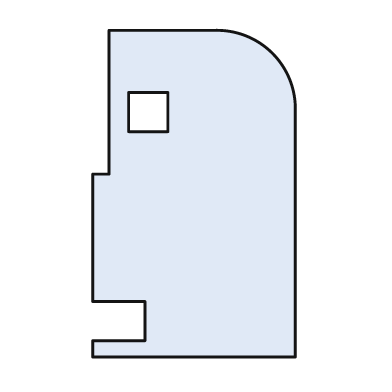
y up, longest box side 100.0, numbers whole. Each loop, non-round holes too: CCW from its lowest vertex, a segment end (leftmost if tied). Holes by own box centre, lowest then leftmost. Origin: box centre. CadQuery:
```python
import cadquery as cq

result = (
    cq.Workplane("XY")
    .moveTo(-31.0, -50.0)
    .lineTo(31.0, -50.0)
    .lineTo(31.0, 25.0)
    .threePointArc((24.0, 43.0), (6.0, 50.0))
    .lineTo(-26.0, 50.0)
    .lineTo(-26.0, 6.0)
    .lineTo(-31.0, 6.0)
    .lineTo(-31.0, -33.0)
    .lineTo(-15.0, -33.0)
    .lineTo(-15.0, -45.0)
    .lineTo(-31.0, -45.0)
    .close()
    .moveTo(-20.0, 19.0)
    .lineTo(-8.0, 19.0)
    .lineTo(-8.0, 31.0)
    .lineTo(-20.0, 31.0)
    .close()
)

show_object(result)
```